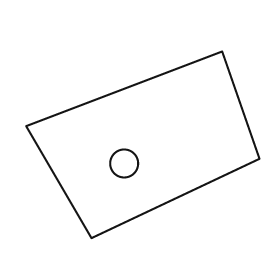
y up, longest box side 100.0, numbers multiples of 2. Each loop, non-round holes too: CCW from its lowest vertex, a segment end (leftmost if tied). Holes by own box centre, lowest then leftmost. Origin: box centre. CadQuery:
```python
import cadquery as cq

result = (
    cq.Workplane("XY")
    .moveTo(-22.0, -40.0)
    .lineTo(50.0, -6.0)
    .lineTo(34.0, 40.0)
    .lineTo(-50.0, 8.0)
    .close()
    .moveTo(-8.0, -8.0)
    .circle(6.0)
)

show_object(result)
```